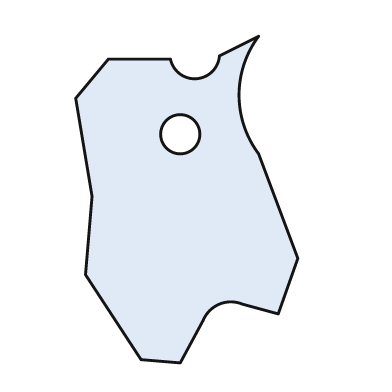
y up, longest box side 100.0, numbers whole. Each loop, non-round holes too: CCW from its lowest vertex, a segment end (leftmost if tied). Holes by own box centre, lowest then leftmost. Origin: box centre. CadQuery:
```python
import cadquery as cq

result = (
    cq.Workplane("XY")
    .moveTo(-2.0, -50.0)
    .lineTo(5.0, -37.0)
    .threePointArc((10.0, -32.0), (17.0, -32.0))
    .lineTo(28.0, -35.0)
    .lineTo(34.0, -18.0)
    .lineTo(22.0, 14.0)
    .threePointArc((16.0, 32.0), (22.0, 50.0))
    .lineTo(10.0, 44.0)
    .threePointArc((3.0, 37.0), (-5.0, 43.0))
    .lineTo(-24.0, 43.0)
    .lineTo(-34.0, 31.0)
    .lineTo(-29.0, 1.0)
    .lineTo(-31.0, -23.0)
    .lineTo(-14.0, -49.0)
    .close()
    .moveTo(-2.0, 20.0)
    .circle(6.0)
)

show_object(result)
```